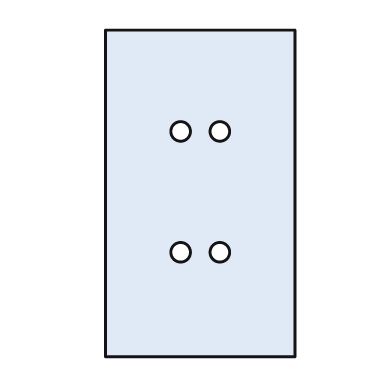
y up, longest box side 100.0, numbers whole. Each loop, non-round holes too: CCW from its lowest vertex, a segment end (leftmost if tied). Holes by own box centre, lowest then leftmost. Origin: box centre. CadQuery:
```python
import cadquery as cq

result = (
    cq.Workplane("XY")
    .moveTo(-29.0, -50.0)
    .lineTo(29.0, -50.0)
    .lineTo(29.0, 50.0)
    .lineTo(-29.0, 50.0)
    .close()
    .moveTo(-6.0, -18.0)
    .circle(3.0)
    .moveTo(6.0, -18.0)
    .circle(3.0)
    .moveTo(-6.0, 19.0)
    .circle(3.0)
    .moveTo(6.0, 19.0)
    .circle(3.0)
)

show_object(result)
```